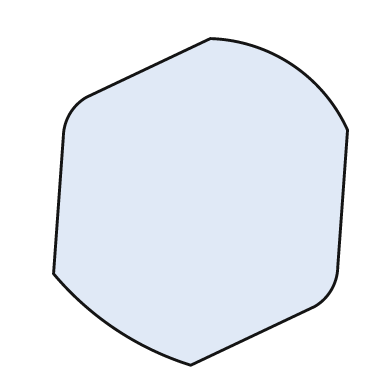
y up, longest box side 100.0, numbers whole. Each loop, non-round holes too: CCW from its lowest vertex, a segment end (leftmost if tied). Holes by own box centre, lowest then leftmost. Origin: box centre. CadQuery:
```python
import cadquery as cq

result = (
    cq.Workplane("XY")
    .moveTo(-3.0, -50.0)
    .lineTo(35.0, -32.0)
    .threePointArc((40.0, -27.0), (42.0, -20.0))
    .lineTo(45.0, 22.0)
    .threePointArc((28.0, 42.0), (3.0, 50.0))
    .lineTo(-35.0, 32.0)
    .threePointArc((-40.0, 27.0), (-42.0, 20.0))
    .lineTo(-45.0, -22.0)
    .threePointArc((-26.0, -39.0), (-3.0, -50.0))
    .close()
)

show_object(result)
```